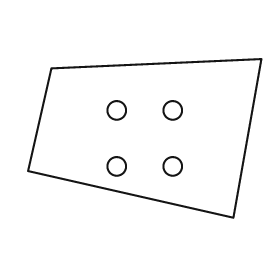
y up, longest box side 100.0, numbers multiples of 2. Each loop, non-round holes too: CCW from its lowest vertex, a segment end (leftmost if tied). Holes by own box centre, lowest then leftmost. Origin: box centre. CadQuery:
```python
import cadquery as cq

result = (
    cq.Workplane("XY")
    .moveTo(38.0, -34.0)
    .lineTo(50.0, 34.0)
    .lineTo(-40.0, 30.0)
    .lineTo(-50.0, -14.0)
    .close()
    .moveTo(-12.0, -12.0)
    .circle(4.0)
    .moveTo(12.0, -12.0)
    .circle(4.0)
    .moveTo(-12.0, 12.0)
    .circle(4.0)
    .moveTo(12.0, 12.0)
    .circle(4.0)
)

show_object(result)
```